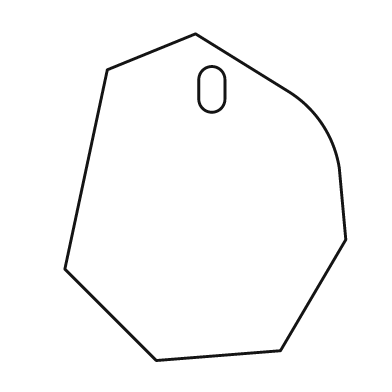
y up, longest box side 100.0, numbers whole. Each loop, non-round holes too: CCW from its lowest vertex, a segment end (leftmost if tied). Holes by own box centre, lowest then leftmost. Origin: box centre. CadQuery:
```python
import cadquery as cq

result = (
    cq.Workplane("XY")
    .moveTo(-15.0, -50.0)
    .lineTo(23.0, -47.0)
    .lineTo(43.0, -13.0)
    .lineTo(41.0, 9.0)
    .threePointArc((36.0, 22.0), (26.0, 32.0))
    .lineTo(-3.0, 50.0)
    .lineTo(-30.0, 39.0)
    .lineTo(-43.0, -22.0)
    .close()
    .moveTo(-2.0, 30.0)
    .threePointArc((2.0, 26.0), (6.0, 30.0))
    .lineTo(6.0, 36.0)
    .threePointArc((2.0, 40.0), (-2.0, 36.0))
    .close()
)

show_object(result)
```